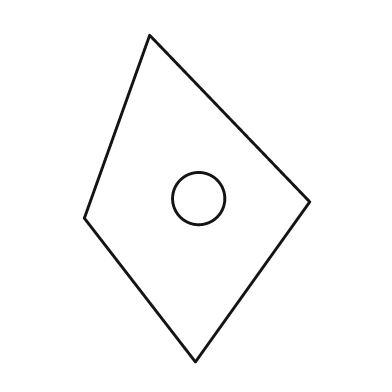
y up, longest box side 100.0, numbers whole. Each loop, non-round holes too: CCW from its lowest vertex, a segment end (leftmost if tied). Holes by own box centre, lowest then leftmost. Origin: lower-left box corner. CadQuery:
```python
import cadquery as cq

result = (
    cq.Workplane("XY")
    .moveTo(34.0, 0.0)
    .lineTo(69.0, 49.0)
    .lineTo(20.0, 100.0)
    .lineTo(0.0, 44.0)
    .close()
    .moveTo(35.0, 50.0)
    .circle(8.0)
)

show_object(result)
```